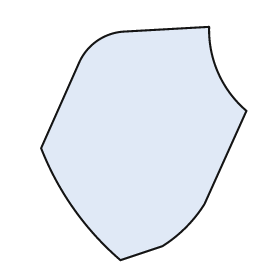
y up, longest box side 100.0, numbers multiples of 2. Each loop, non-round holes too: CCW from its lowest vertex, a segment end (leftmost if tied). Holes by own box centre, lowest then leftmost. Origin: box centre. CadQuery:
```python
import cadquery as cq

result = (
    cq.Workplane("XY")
    .moveTo(-10.0, -50.0)
    .lineTo(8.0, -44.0)
    .threePointArc((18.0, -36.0), (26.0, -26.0))
    .lineTo(44.0, 14.0)
    .threePointArc((32.0, 30.0), (28.0, 50.0))
    .lineTo(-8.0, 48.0)
    .threePointArc((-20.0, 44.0), (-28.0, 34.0))
    .lineTo(-44.0, -2.0)
    .threePointArc((-30.0, -28.0), (-10.0, -50.0))
    .close()
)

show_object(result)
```